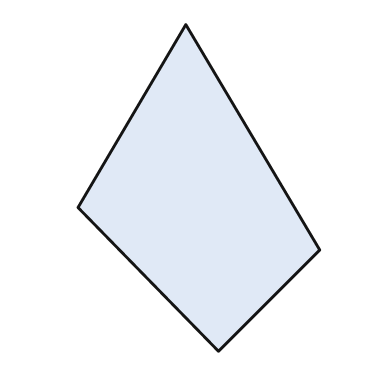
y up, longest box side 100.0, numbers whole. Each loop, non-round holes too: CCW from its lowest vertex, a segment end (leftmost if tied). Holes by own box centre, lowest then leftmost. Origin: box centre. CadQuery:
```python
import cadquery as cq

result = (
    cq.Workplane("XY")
    .moveTo(6.0, -50.0)
    .lineTo(37.0, -19.0)
    .lineTo(-4.0, 50.0)
    .lineTo(-37.0, -6.0)
    .close()
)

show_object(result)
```